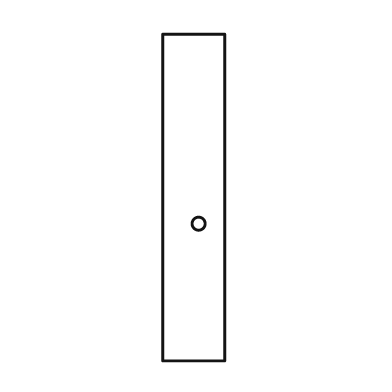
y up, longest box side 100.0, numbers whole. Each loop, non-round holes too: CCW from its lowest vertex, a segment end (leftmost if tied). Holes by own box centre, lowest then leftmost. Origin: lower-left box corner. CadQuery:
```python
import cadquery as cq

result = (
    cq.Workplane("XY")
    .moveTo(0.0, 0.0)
    .lineTo(19.0, 0.0)
    .lineTo(19.0, 100.0)
    .lineTo(0.0, 100.0)
    .close()
    .moveTo(11.0, 42.0)
    .circle(2.0)
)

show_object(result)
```